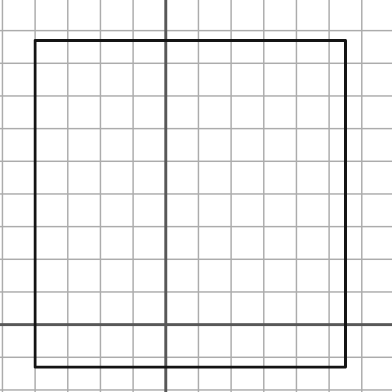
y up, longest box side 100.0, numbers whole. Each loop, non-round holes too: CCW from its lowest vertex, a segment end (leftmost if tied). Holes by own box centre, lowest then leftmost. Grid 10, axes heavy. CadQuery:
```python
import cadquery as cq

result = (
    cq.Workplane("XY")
    .moveTo(-40.0, -13.0)
    .lineTo(55.0, -13.0)
    .lineTo(55.0, 87.0)
    .lineTo(-40.0, 87.0)
    .close()
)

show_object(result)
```